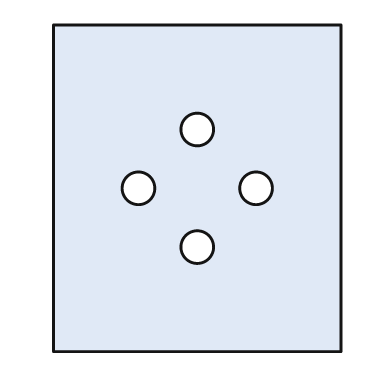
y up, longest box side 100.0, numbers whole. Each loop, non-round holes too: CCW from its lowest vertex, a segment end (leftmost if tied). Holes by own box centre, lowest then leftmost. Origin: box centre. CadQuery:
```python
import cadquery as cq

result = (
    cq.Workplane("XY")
    .moveTo(-44.0, -50.0)
    .lineTo(44.0, -50.0)
    .lineTo(44.0, 50.0)
    .lineTo(-44.0, 50.0)
    .close()
    .moveTo(0.0, -18.0)
    .circle(5.0)
    .moveTo(-18.0, 0.0)
    .circle(5.0)
    .moveTo(18.0, 0.0)
    .circle(5.0)
    .moveTo(0.0, 18.0)
    .circle(5.0)
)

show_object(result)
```